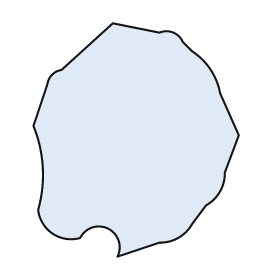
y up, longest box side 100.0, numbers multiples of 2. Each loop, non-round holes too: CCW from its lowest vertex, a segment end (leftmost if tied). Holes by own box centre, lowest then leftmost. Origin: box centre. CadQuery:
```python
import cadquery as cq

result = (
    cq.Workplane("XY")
    .moveTo(-8.0, -50.0)
    .lineTo(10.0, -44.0)
    .threePointArc((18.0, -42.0), (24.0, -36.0))
    .lineTo(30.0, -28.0)
    .threePointArc((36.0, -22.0), (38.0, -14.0))
    .lineTo(44.0, 2.0)
    .lineTo(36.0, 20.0)
    .threePointArc((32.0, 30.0), (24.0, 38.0))
    .lineTo(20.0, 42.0)
    .threePointArc((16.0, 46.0), (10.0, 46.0))
    .lineTo(-10.0, 50.0)
    .lineTo(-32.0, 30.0)
    .threePointArc((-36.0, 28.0), (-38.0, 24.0))
    .lineTo(-44.0, 6.0)
    .threePointArc((-40.0, -12.0), (-42.0, -30.0))
    .threePointArc((-36.0, -40.0), (-24.0, -42.0))
    .threePointArc((-12.0, -38.0), (-8.0, -50.0))
    .close()
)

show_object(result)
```